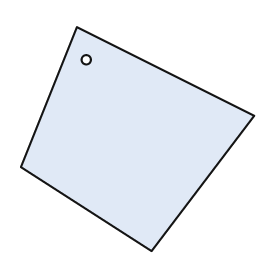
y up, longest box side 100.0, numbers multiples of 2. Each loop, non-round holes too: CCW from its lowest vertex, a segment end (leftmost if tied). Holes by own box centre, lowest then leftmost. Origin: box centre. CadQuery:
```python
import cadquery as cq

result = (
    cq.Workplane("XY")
    .moveTo(6.0, -48.0)
    .lineTo(50.0, 10.0)
    .lineTo(-26.0, 48.0)
    .lineTo(-50.0, -12.0)
    .close()
    .moveTo(-22.0, 34.0)
    .circle(2.0)
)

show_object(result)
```